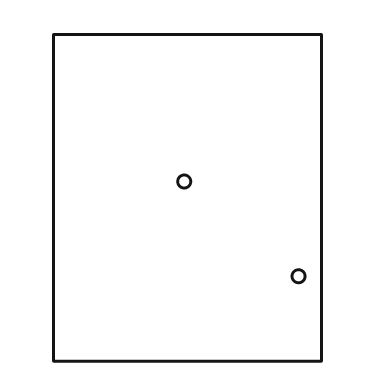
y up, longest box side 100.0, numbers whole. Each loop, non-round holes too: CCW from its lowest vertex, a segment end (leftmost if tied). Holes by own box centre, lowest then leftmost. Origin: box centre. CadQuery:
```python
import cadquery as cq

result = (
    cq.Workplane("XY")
    .moveTo(-41.0, -50.0)
    .lineTo(41.0, -50.0)
    .lineTo(41.0, 50.0)
    .lineTo(-41.0, 50.0)
    .close()
    .moveTo(34.0, -24.0)
    .circle(2.0)
    .moveTo(-1.0, 5.0)
    .circle(2.0)
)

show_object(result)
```